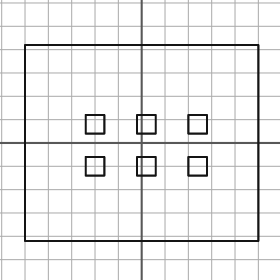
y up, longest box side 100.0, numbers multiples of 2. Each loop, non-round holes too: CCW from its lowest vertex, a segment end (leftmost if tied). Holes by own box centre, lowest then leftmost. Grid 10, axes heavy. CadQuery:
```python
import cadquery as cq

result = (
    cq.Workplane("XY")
    .moveTo(-50.0, -42.0)
    .lineTo(50.0, -42.0)
    .lineTo(50.0, 42.0)
    .lineTo(-50.0, 42.0)
    .close()
    .moveTo(-24.0, -14.0)
    .lineTo(-16.0, -14.0)
    .lineTo(-16.0, -6.0)
    .lineTo(-24.0, -6.0)
    .close()
    .moveTo(-2.0, -14.0)
    .lineTo(6.0, -14.0)
    .lineTo(6.0, -6.0)
    .lineTo(-2.0, -6.0)
    .close()
    .moveTo(20.0, -14.0)
    .lineTo(28.0, -14.0)
    .lineTo(28.0, -6.0)
    .lineTo(20.0, -6.0)
    .close()
    .moveTo(-24.0, 4.0)
    .lineTo(-16.0, 4.0)
    .lineTo(-16.0, 12.0)
    .lineTo(-24.0, 12.0)
    .close()
    .moveTo(-2.0, 4.0)
    .lineTo(6.0, 4.0)
    .lineTo(6.0, 12.0)
    .lineTo(-2.0, 12.0)
    .close()
    .moveTo(20.0, 4.0)
    .lineTo(28.0, 4.0)
    .lineTo(28.0, 12.0)
    .lineTo(20.0, 12.0)
    .close()
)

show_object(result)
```